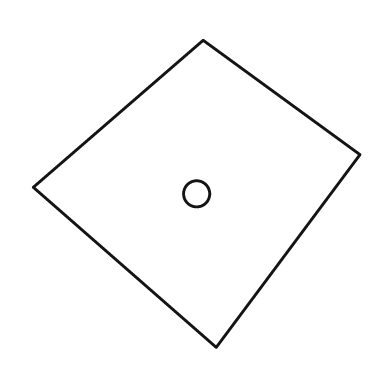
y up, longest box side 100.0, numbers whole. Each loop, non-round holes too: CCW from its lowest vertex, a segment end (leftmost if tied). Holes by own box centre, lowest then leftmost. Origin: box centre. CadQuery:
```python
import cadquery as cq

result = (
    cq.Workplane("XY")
    .moveTo(6.0, -47.0)
    .lineTo(50.0, 12.0)
    .lineTo(2.0, 47.0)
    .lineTo(-50.0, 2.0)
    .close()
    .moveTo(0.0, 0.0)
    .circle(4.0)
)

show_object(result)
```